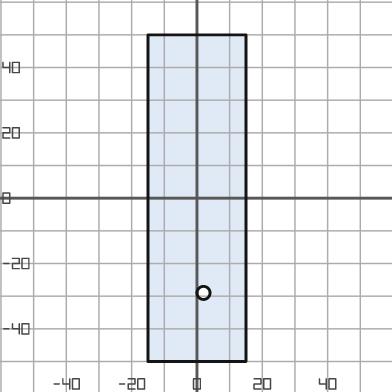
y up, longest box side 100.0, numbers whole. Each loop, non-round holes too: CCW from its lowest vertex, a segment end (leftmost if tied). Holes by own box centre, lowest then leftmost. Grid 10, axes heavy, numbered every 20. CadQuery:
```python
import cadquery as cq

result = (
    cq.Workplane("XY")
    .moveTo(-15.0, -50.0)
    .lineTo(15.0, -50.0)
    .lineTo(15.0, 50.0)
    .lineTo(-15.0, 50.0)
    .close()
    .moveTo(2.0, -29.0)
    .circle(2.0)
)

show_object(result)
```